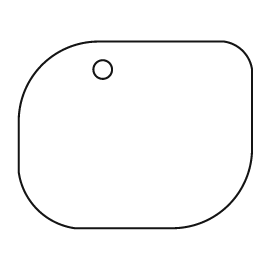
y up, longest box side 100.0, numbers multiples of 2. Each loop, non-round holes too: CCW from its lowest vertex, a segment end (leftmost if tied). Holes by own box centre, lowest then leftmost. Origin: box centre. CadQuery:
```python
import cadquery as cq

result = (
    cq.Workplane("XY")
    .moveTo(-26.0, -40.0)
    .lineTo(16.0, -40.0)
    .threePointArc((40.0, -30.0), (50.0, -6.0))
    .lineTo(50.0, 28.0)
    .threePointArc((46.0, 36.0), (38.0, 40.0))
    .lineTo(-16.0, 40.0)
    .threePointArc((-40.0, 30.0), (-50.0, 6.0))
    .lineTo(-50.0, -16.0)
    .threePointArc((-42.0, -32.0), (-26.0, -40.0))
    .close()
    .moveTo(-14.0, 28.0)
    .circle(4.0)
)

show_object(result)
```